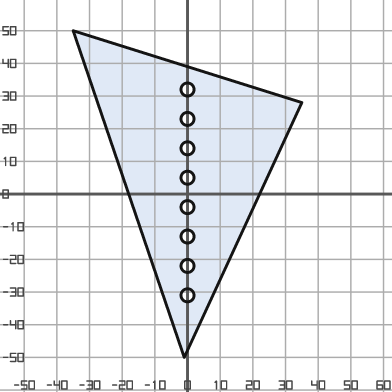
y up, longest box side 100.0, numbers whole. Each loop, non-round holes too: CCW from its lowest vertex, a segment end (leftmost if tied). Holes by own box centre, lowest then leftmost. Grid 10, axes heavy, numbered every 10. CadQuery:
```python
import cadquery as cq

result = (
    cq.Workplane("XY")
    .moveTo(-1.0, -50.0)
    .lineTo(35.0, 28.0)
    .lineTo(-35.0, 50.0)
    .close()
    .moveTo(0.0, -31.0)
    .circle(2.0)
    .moveTo(0.0, -22.0)
    .circle(2.0)
    .moveTo(0.0, -13.0)
    .circle(2.0)
    .moveTo(0.0, -4.0)
    .circle(2.0)
    .moveTo(0.0, 5.0)
    .circle(2.0)
    .moveTo(0.0, 14.0)
    .circle(2.0)
    .moveTo(0.0, 23.0)
    .circle(2.0)
    .moveTo(0.0, 32.0)
    .circle(2.0)
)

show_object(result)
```